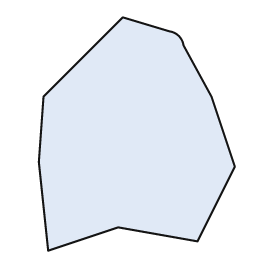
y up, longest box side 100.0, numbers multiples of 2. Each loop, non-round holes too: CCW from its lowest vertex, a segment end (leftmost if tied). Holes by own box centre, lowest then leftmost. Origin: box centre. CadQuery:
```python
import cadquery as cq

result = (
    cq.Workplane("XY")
    .moveTo(-38.0, -50.0)
    .lineTo(-8.0, -40.0)
    .lineTo(26.0, -46.0)
    .lineTo(42.0, -14.0)
    .lineTo(32.0, 16.0)
    .lineTo(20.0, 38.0)
    .threePointArc((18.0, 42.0), (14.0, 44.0))
    .lineTo(-6.0, 50.0)
    .lineTo(-40.0, 16.0)
    .lineTo(-42.0, -12.0)
    .close()
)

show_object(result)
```